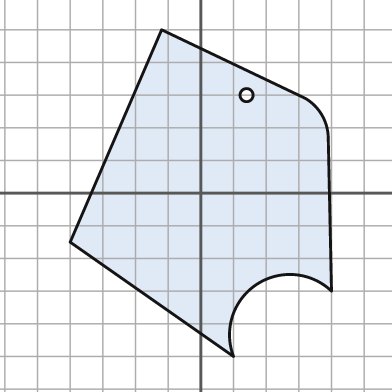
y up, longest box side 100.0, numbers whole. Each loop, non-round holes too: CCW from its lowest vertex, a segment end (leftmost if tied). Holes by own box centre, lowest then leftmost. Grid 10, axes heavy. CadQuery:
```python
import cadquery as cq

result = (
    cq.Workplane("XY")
    .moveTo(10.0, -50.0)
    .threePointArc((17.0, -28.0), (40.0, -30.0))
    .lineTo(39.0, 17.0)
    .threePointArc((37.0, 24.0), (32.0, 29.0))
    .lineTo(-12.0, 50.0)
    .lineTo(-40.0, -15.0)
    .close()
    .moveTo(14.0, 30.0)
    .circle(2.0)
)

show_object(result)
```